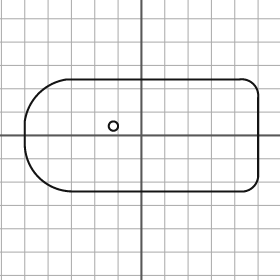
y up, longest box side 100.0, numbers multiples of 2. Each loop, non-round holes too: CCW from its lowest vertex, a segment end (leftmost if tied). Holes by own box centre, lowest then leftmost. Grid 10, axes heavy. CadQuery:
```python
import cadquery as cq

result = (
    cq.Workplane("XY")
    .moveTo(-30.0, -24.0)
    .lineTo(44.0, -24.0)
    .threePointArc((48.0, -22.0), (50.0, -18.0))
    .lineTo(50.0, 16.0)
    .threePointArc((48.0, 22.0), (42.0, 24.0))
    .lineTo(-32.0, 24.0)
    .threePointArc((-44.0, 18.0), (-50.0, 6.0))
    .lineTo(-50.0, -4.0)
    .threePointArc((-44.0, -18.0), (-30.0, -24.0))
    .close()
    .moveTo(-12.0, 4.0)
    .circle(2.0)
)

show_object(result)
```